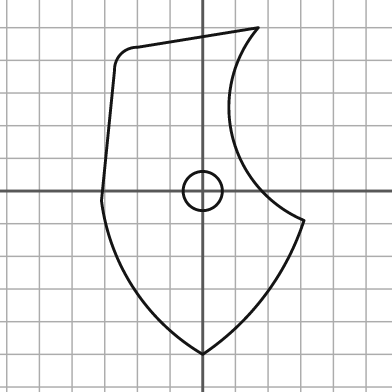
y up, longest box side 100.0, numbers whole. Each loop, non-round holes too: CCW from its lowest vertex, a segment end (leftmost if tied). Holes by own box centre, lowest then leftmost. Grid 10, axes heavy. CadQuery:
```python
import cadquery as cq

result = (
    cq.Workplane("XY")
    .moveTo(0.0, -50.0)
    .threePointArc((19.0, -32.0), (31.0, -9.0))
    .threePointArc((9.0, 17.0), (17.0, 50.0))
    .lineTo(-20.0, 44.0)
    .threePointArc((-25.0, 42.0), (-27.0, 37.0))
    .lineTo(-31.0, -3.0)
    .threePointArc((-21.0, -30.0), (0.0, -50.0))
    .close()
    .moveTo(0.0, 0.0)
    .circle(6.0)
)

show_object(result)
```